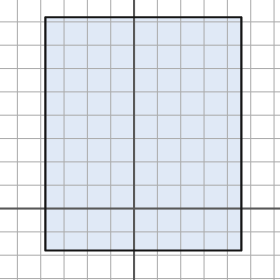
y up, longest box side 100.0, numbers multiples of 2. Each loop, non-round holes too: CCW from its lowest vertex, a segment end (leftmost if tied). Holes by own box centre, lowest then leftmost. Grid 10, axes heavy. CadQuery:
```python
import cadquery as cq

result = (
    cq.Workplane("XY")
    .moveTo(-38.0, -18.0)
    .lineTo(46.0, -18.0)
    .lineTo(46.0, 82.0)
    .lineTo(-38.0, 82.0)
    .close()
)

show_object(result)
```